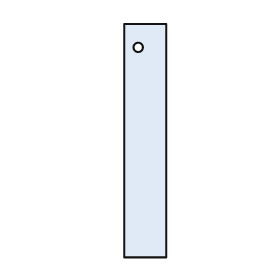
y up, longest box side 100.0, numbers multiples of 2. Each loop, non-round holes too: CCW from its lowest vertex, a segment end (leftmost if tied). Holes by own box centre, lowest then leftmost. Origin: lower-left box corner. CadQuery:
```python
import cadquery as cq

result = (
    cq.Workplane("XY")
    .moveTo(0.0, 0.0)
    .lineTo(18.0, 0.0)
    .lineTo(18.0, 100.0)
    .lineTo(0.0, 100.0)
    .close()
    .moveTo(6.0, 90.0)
    .circle(2.0)
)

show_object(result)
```